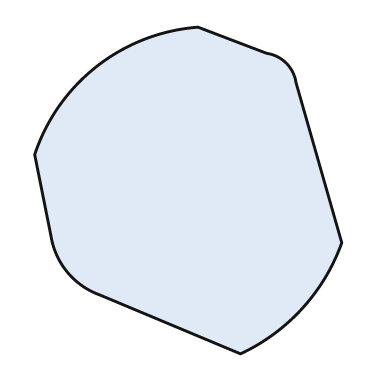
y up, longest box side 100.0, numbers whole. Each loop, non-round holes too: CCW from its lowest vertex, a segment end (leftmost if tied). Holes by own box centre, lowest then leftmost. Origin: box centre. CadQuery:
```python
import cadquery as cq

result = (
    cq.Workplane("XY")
    .moveTo(16.0, -50.0)
    .threePointArc((35.0, -36.0), (47.0, -16.0))
    .lineTo(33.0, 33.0)
    .threePointArc((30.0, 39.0), (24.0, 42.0))
    .lineTo(3.0, 50.0)
    .threePointArc((-28.0, 38.0), (-47.0, 11.0))
    .lineTo(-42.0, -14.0)
    .threePointArc((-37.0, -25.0), (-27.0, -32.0))
    .close()
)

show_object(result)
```